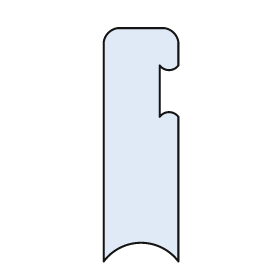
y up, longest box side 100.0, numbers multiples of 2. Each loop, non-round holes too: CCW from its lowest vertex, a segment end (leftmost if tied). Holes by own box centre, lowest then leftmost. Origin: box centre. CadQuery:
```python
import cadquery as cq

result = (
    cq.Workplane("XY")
    .moveTo(-16.0, -50.0)
    .threePointArc((0.0, -42.0), (16.0, -50.0))
    .lineTo(16.0, 12.0)
    .threePointArc((12.0, 14.0), (8.0, 12.0))
    .lineTo(8.0, 34.0)
    .threePointArc((12.0, 32.0), (16.0, 34.0))
    .lineTo(16.0, 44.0)
    .threePointArc((14.0, 48.0), (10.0, 50.0))
    .lineTo(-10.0, 50.0)
    .threePointArc((-14.0, 48.0), (-16.0, 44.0))
    .close()
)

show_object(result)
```